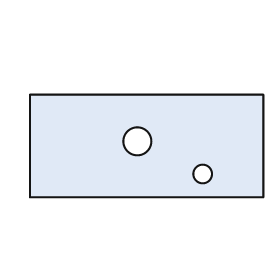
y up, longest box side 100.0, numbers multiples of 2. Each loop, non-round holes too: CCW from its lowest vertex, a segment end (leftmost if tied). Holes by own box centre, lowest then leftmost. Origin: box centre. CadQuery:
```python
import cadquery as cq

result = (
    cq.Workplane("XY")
    .moveTo(-50.0, -22.0)
    .lineTo(50.0, -22.0)
    .lineTo(50.0, 22.0)
    .lineTo(-50.0, 22.0)
    .close()
    .moveTo(24.0, -12.0)
    .circle(4.0)
    .moveTo(-4.0, 2.0)
    .circle(6.0)
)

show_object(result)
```